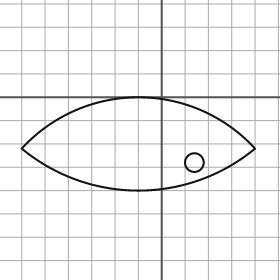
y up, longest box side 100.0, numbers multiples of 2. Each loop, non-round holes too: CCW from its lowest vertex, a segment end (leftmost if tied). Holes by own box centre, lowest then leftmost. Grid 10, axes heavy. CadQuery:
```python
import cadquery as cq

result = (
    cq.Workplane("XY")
    .moveTo(-60.0, -22.0)
    .threePointArc((-10.0, -40.0), (40.0, -22.0))
    .threePointArc((-10.0, 0.0), (-60.0, -22.0))
    .close()
    .moveTo(14.0, -28.0)
    .circle(4.0)
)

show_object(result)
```